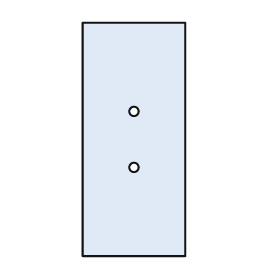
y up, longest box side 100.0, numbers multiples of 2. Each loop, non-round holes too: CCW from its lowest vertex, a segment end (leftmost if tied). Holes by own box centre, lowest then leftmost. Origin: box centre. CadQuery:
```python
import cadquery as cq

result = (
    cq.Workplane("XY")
    .moveTo(-22.0, -50.0)
    .lineTo(22.0, -50.0)
    .lineTo(22.0, 50.0)
    .lineTo(-22.0, 50.0)
    .close()
    .moveTo(0.0, -12.0)
    .circle(2.0)
    .moveTo(0.0, 12.0)
    .circle(2.0)
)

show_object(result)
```